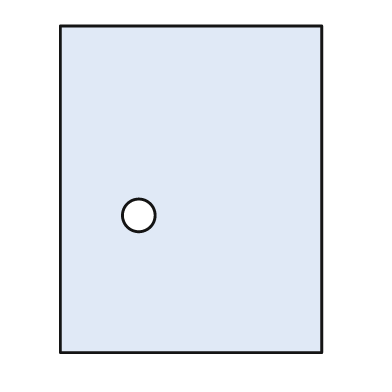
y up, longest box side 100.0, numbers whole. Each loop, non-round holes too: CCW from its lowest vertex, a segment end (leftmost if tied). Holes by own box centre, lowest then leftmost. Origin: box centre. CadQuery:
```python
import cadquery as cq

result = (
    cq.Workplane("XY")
    .moveTo(-40.0, -50.0)
    .lineTo(40.0, -50.0)
    .lineTo(40.0, 50.0)
    .lineTo(-40.0, 50.0)
    .close()
    .moveTo(-16.0, -8.0)
    .circle(5.0)
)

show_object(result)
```